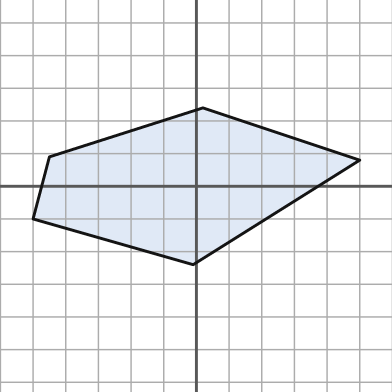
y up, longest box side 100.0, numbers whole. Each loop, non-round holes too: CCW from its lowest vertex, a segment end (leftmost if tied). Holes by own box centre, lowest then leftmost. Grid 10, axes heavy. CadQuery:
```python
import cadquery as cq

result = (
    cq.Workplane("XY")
    .moveTo(-1.0, -24.0)
    .lineTo(50.0, 8.0)
    .lineTo(2.0, 24.0)
    .lineTo(-45.0, 9.0)
    .lineTo(-50.0, -10.0)
    .close()
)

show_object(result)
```